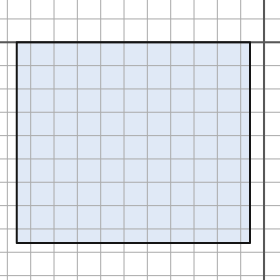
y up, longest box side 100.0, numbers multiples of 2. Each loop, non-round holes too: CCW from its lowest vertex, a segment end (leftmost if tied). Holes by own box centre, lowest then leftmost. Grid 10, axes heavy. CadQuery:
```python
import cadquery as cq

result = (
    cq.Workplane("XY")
    .moveTo(-106.0, -86.0)
    .lineTo(-6.0, -86.0)
    .lineTo(-6.0, 0.0)
    .lineTo(-106.0, 0.0)
    .close()
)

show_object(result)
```